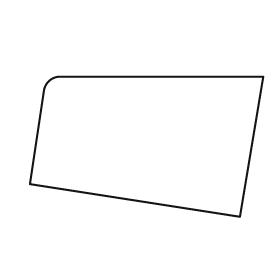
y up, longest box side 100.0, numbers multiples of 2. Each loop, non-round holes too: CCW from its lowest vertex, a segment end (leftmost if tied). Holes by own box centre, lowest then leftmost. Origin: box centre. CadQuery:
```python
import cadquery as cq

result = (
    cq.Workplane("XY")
    .moveTo(40.0, -30.0)
    .lineTo(50.0, 30.0)
    .lineTo(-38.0, 30.0)
    .threePointArc((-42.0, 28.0), (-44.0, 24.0))
    .lineTo(-50.0, -16.0)
    .close()
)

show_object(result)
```